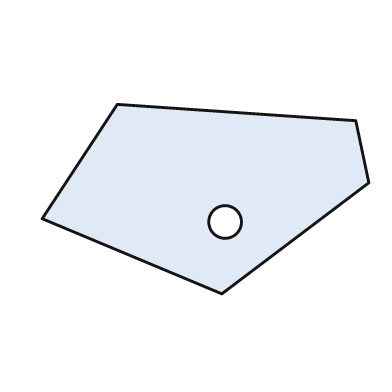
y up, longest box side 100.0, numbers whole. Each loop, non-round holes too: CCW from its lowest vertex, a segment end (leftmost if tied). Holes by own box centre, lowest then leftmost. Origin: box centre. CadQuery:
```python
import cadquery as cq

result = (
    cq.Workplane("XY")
    .moveTo(5.0, -29.0)
    .lineTo(50.0, 5.0)
    .lineTo(46.0, 24.0)
    .lineTo(-27.0, 29.0)
    .lineTo(-50.0, -6.0)
    .close()
    .moveTo(6.0, -7.0)
    .circle(5.0)
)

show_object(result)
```